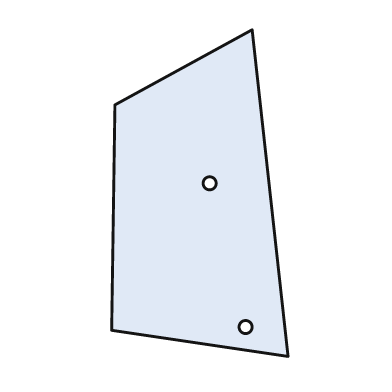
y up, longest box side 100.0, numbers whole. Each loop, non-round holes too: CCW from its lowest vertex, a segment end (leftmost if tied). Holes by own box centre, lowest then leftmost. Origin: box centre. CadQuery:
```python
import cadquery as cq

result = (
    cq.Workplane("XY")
    .moveTo(27.0, -50.0)
    .lineTo(16.0, 50.0)
    .lineTo(-26.0, 27.0)
    .lineTo(-27.0, -42.0)
    .close()
    .moveTo(14.0, -41.0)
    .circle(2.0)
    .moveTo(3.0, 3.0)
    .circle(2.0)
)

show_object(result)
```